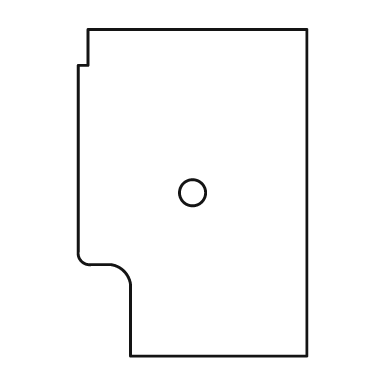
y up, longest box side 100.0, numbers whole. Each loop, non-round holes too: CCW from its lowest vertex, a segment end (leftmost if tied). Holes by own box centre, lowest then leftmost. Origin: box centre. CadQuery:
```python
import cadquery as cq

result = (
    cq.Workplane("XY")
    .moveTo(-19.0, -50.0)
    .lineTo(35.0, -50.0)
    .lineTo(35.0, 50.0)
    .lineTo(-32.0, 50.0)
    .lineTo(-32.0, 39.0)
    .lineTo(-35.0, 39.0)
    .lineTo(-35.0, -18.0)
    .threePointArc((-34.0, -21.0), (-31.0, -22.0))
    .lineTo(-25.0, -22.0)
    .threePointArc((-21.0, -24.0), (-19.0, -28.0))
    .close()
    .moveTo(0.0, 0.0)
    .circle(4.0)
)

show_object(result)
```